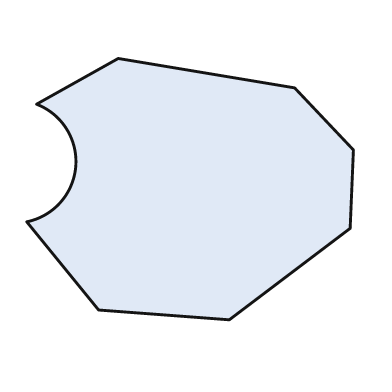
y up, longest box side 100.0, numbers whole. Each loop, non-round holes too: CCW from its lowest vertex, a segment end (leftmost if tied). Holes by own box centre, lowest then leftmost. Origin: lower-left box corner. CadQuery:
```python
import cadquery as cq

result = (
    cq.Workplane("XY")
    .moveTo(62.0, 0.0)
    .lineTo(99.0, 28.0)
    .lineTo(100.0, 52.0)
    .lineTo(82.0, 71.0)
    .lineTo(28.0, 80.0)
    .lineTo(3.0, 66.0)
    .threePointArc((15.0, 47.0), (0.0, 30.0))
    .lineTo(22.0, 3.0)
    .close()
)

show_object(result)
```